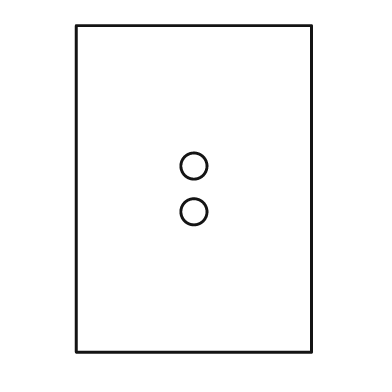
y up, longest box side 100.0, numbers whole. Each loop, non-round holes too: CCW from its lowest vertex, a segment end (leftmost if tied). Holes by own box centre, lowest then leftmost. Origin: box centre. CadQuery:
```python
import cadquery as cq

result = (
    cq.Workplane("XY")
    .moveTo(-36.0, -50.0)
    .lineTo(36.0, -50.0)
    .lineTo(36.0, 50.0)
    .lineTo(-36.0, 50.0)
    .close()
    .moveTo(0.0, -7.0)
    .circle(4.0)
    .moveTo(0.0, 7.0)
    .circle(4.0)
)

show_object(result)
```